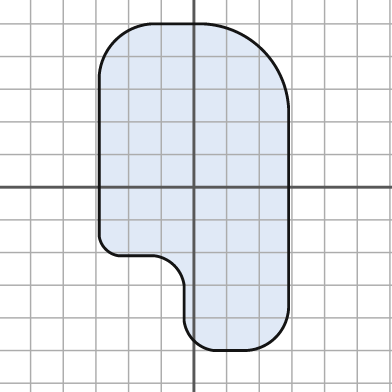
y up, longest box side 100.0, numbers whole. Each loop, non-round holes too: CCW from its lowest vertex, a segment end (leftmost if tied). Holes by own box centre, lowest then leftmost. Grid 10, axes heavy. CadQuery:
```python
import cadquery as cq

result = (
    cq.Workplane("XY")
    .moveTo(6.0, -50.0)
    .lineTo(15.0, -50.0)
    .threePointArc((25.0, -46.0), (29.0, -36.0))
    .lineTo(29.0, 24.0)
    .threePointArc((21.0, 42.0), (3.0, 50.0))
    .lineTo(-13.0, 50.0)
    .threePointArc((-24.0, 45.0), (-29.0, 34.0))
    .lineTo(-29.0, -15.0)
    .threePointArc((-27.0, -19.0), (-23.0, -21.0))
    .lineTo(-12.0, -21.0)
    .threePointArc((-6.0, -24.0), (-3.0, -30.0))
    .lineTo(-3.0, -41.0)
    .threePointArc((0.0, -47.0), (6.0, -50.0))
    .close()
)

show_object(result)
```